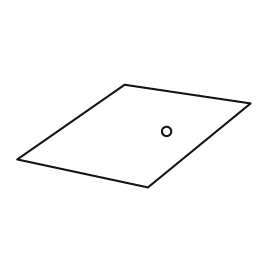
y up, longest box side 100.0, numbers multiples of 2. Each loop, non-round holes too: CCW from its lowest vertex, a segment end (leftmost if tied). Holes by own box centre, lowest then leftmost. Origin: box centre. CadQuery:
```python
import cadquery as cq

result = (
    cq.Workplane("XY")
    .moveTo(6.0, -22.0)
    .lineTo(50.0, 14.0)
    .lineTo(-4.0, 22.0)
    .lineTo(-50.0, -10.0)
    .close()
    .moveTo(14.0, 2.0)
    .circle(2.0)
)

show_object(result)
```